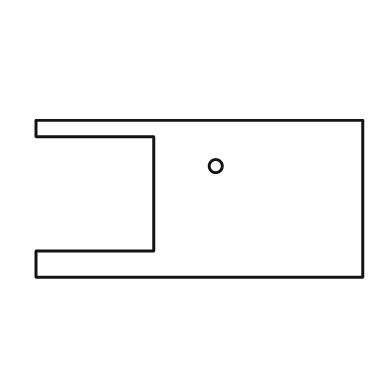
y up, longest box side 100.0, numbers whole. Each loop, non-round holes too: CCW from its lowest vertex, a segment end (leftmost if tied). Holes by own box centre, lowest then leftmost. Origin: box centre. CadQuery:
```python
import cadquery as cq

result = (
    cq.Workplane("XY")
    .moveTo(-50.0, -24.0)
    .lineTo(50.0, -24.0)
    .lineTo(50.0, 24.0)
    .lineTo(-50.0, 24.0)
    .lineTo(-50.0, 19.0)
    .lineTo(-14.0, 19.0)
    .lineTo(-14.0, -16.0)
    .lineTo(-50.0, -16.0)
    .close()
    .moveTo(5.0, 10.0)
    .circle(2.0)
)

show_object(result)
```